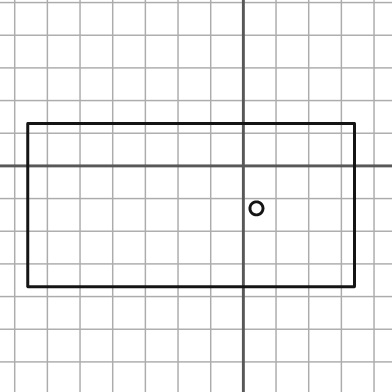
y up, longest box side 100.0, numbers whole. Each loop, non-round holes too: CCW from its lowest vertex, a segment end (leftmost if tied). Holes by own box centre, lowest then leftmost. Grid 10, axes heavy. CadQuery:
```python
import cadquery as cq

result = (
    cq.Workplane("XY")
    .moveTo(-66.0, -37.0)
    .lineTo(34.0, -37.0)
    .lineTo(34.0, 13.0)
    .lineTo(-66.0, 13.0)
    .close()
    .moveTo(4.0, -13.0)
    .circle(2.0)
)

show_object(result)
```